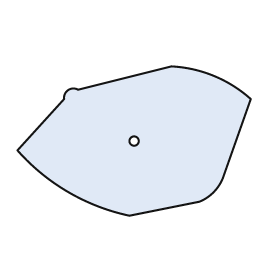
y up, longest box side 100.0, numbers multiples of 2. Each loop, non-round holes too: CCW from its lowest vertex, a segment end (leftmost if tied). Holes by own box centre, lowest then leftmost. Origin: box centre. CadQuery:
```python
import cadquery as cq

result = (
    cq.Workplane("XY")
    .moveTo(-2.0, -32.0)
    .lineTo(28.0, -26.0)
    .threePointArc((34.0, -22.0), (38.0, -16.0))
    .lineTo(50.0, 18.0)
    .threePointArc((34.0, 28.0), (16.0, 32.0))
    .lineTo(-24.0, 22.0)
    .threePointArc((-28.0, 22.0), (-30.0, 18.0))
    .lineTo(-50.0, -4.0)
    .threePointArc((-28.0, -22.0), (-2.0, -32.0))
    .close()
    .moveTo(0.0, 0.0)
    .circle(2.0)
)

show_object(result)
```